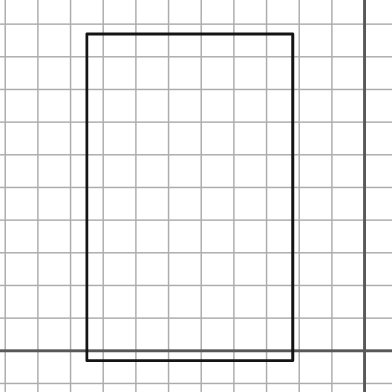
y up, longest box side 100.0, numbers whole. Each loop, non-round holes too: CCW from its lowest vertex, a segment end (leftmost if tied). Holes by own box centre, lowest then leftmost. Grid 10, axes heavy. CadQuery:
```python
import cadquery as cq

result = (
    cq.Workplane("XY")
    .moveTo(-85.0, -3.0)
    .lineTo(-22.0, -3.0)
    .lineTo(-22.0, 97.0)
    .lineTo(-85.0, 97.0)
    .close()
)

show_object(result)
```